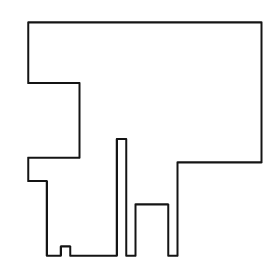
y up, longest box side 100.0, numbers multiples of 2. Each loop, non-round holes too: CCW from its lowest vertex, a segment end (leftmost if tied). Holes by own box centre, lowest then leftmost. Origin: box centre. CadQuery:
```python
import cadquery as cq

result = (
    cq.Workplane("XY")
    .moveTo(-42.0, -50.0)
    .lineTo(-36.0, -50.0)
    .lineTo(-36.0, -46.0)
    .lineTo(-32.0, -46.0)
    .lineTo(-32.0, -50.0)
    .lineTo(-12.0, -50.0)
    .lineTo(-12.0, 0.0)
    .lineTo(-8.0, 0.0)
    .lineTo(-8.0, -50.0)
    .lineTo(-4.0, -50.0)
    .lineTo(-4.0, -28.0)
    .lineTo(10.0, -28.0)
    .lineTo(10.0, -50.0)
    .lineTo(14.0, -50.0)
    .lineTo(14.0, -10.0)
    .lineTo(50.0, -10.0)
    .lineTo(50.0, 50.0)
    .lineTo(-50.0, 50.0)
    .lineTo(-50.0, 24.0)
    .lineTo(-28.0, 24.0)
    .lineTo(-28.0, -8.0)
    .lineTo(-50.0, -8.0)
    .lineTo(-50.0, -18.0)
    .lineTo(-42.0, -18.0)
    .close()
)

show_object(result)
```